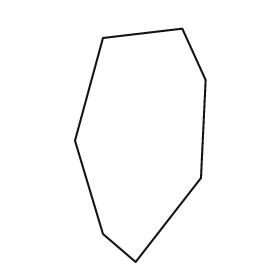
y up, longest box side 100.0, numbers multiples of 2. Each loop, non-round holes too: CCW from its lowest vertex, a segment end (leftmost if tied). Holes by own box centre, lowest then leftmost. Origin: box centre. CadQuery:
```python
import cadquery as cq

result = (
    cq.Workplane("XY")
    .moveTo(-2.0, -50.0)
    .lineTo(26.0, -14.0)
    .lineTo(28.0, 28.0)
    .lineTo(18.0, 50.0)
    .lineTo(-16.0, 46.0)
    .lineTo(-28.0, 2.0)
    .lineTo(-16.0, -38.0)
    .close()
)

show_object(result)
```